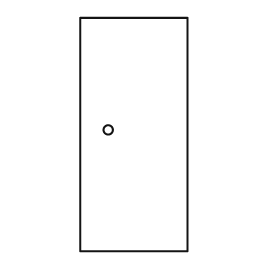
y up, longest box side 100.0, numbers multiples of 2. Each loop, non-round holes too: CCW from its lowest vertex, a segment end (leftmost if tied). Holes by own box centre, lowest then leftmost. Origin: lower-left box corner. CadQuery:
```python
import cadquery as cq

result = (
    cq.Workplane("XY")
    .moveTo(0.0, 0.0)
    .lineTo(46.0, 0.0)
    .lineTo(46.0, 100.0)
    .lineTo(0.0, 100.0)
    .close()
    .moveTo(12.0, 52.0)
    .circle(2.0)
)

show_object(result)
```